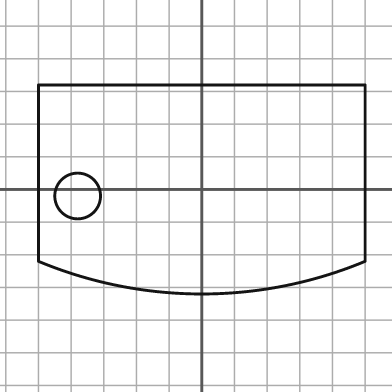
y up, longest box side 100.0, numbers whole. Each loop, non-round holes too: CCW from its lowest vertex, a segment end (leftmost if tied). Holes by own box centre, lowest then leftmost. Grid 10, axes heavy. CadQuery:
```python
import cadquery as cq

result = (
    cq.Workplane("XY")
    .moveTo(-50.0, -22.0)
    .threePointArc((0.0, -32.0), (50.0, -22.0))
    .lineTo(50.0, 32.0)
    .lineTo(-50.0, 32.0)
    .close()
    .moveTo(-38.0, -2.0)
    .circle(7.0)
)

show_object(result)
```